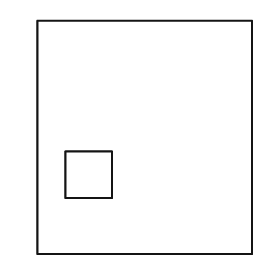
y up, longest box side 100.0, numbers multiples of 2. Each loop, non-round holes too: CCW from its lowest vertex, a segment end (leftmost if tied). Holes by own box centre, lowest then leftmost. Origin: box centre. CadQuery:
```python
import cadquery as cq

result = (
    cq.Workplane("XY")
    .moveTo(-46.0, -50.0)
    .lineTo(46.0, -50.0)
    .lineTo(46.0, 50.0)
    .lineTo(-46.0, 50.0)
    .close()
    .moveTo(-34.0, -26.0)
    .lineTo(-14.0, -26.0)
    .lineTo(-14.0, -6.0)
    .lineTo(-34.0, -6.0)
    .close()
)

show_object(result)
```